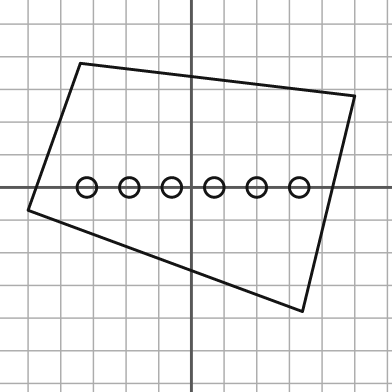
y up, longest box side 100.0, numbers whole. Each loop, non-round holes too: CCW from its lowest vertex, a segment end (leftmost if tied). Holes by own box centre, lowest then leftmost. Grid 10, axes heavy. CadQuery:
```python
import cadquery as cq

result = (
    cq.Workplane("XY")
    .moveTo(34.0, -38.0)
    .lineTo(50.0, 28.0)
    .lineTo(-34.0, 38.0)
    .lineTo(-50.0, -7.0)
    .close()
    .moveTo(-32.0, 0.0)
    .circle(3.0)
    .moveTo(-19.0, 0.0)
    .circle(3.0)
    .moveTo(-6.0, 0.0)
    .circle(3.0)
    .moveTo(7.0, 0.0)
    .circle(3.0)
    .moveTo(20.0, 0.0)
    .circle(3.0)
    .moveTo(33.0, 0.0)
    .circle(3.0)
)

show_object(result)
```